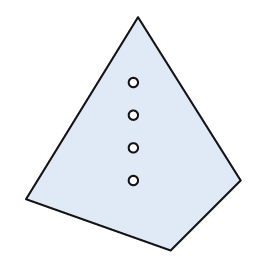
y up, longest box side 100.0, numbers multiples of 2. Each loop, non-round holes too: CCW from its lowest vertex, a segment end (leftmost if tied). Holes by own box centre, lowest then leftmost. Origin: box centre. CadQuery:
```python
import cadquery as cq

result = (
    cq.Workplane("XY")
    .moveTo(16.0, -50.0)
    .lineTo(46.0, -20.0)
    .lineTo(2.0, 50.0)
    .lineTo(-46.0, -28.0)
    .close()
    .moveTo(0.0, -20.0)
    .circle(2.0)
    .moveTo(0.0, -6.0)
    .circle(2.0)
    .moveTo(0.0, 8.0)
    .circle(2.0)
    .moveTo(0.0, 22.0)
    .circle(2.0)
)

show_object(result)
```